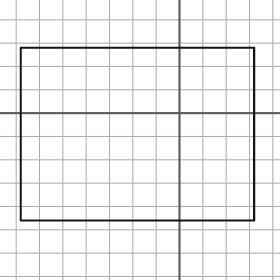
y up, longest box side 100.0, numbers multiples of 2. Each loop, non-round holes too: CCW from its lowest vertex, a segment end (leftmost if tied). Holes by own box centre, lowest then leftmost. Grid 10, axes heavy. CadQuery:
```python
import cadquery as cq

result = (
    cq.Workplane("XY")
    .moveTo(-68.0, -46.0)
    .lineTo(32.0, -46.0)
    .lineTo(32.0, 28.0)
    .lineTo(-68.0, 28.0)
    .close()
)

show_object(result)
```